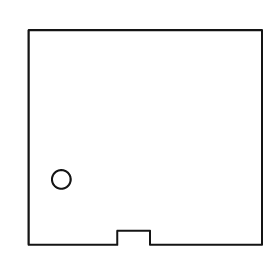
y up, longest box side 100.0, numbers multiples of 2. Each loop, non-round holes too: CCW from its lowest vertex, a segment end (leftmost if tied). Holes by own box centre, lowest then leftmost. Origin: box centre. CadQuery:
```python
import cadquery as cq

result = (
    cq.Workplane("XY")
    .moveTo(-50.0, -46.0)
    .lineTo(-12.0, -46.0)
    .lineTo(-12.0, -40.0)
    .lineTo(2.0, -40.0)
    .lineTo(2.0, -46.0)
    .lineTo(50.0, -46.0)
    .lineTo(50.0, 46.0)
    .lineTo(-50.0, 46.0)
    .close()
    .moveTo(-36.0, -18.0)
    .circle(4.0)
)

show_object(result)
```